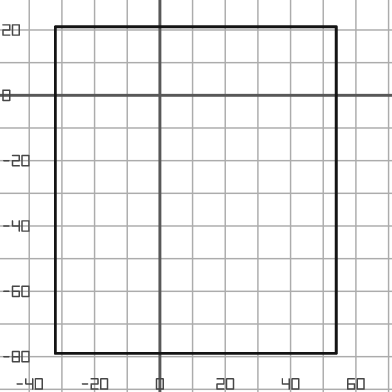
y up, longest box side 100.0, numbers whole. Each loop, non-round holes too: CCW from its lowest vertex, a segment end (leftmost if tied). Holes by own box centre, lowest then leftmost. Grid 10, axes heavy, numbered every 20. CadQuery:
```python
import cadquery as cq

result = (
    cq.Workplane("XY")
    .moveTo(-32.0, -79.0)
    .lineTo(54.0, -79.0)
    .lineTo(54.0, 21.0)
    .lineTo(-32.0, 21.0)
    .close()
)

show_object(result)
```